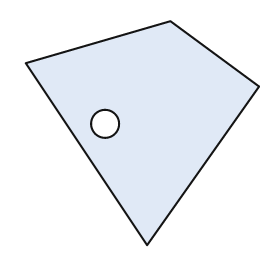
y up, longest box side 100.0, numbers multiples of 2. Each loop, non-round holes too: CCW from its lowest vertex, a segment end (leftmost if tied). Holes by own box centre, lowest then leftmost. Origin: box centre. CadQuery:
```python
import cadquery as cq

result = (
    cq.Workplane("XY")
    .moveTo(2.0, -48.0)
    .lineTo(50.0, 20.0)
    .lineTo(12.0, 48.0)
    .lineTo(-50.0, 30.0)
    .close()
    .moveTo(-16.0, 4.0)
    .circle(6.0)
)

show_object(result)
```